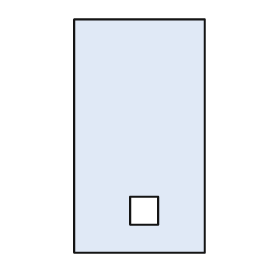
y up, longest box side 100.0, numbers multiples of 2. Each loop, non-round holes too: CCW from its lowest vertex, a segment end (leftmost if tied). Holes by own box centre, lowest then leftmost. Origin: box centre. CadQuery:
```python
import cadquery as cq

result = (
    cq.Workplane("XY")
    .moveTo(-28.0, -50.0)
    .lineTo(28.0, -50.0)
    .lineTo(28.0, 50.0)
    .lineTo(-28.0, 50.0)
    .close()
    .moveTo(-4.0, -38.0)
    .lineTo(8.0, -38.0)
    .lineTo(8.0, -26.0)
    .lineTo(-4.0, -26.0)
    .close()
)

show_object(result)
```